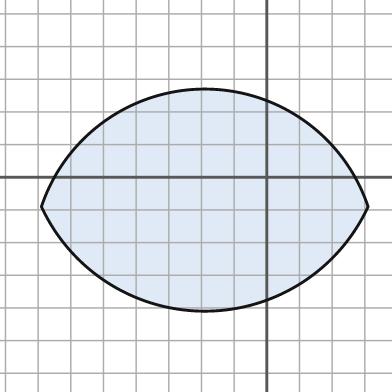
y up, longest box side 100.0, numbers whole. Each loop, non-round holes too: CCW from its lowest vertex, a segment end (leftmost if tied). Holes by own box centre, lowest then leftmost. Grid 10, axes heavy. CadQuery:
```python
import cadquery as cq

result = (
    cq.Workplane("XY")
    .moveTo(-69.0, -9.0)
    .threePointArc((-19.0, -41.0), (31.0, -9.0))
    .threePointArc((-19.0, 27.0), (-69.0, -9.0))
    .close()
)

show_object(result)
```